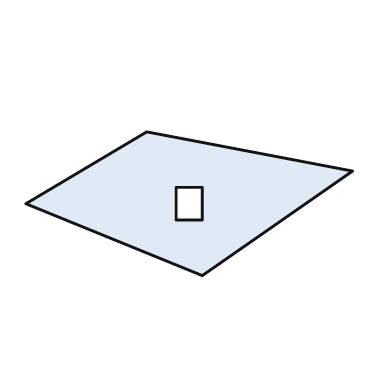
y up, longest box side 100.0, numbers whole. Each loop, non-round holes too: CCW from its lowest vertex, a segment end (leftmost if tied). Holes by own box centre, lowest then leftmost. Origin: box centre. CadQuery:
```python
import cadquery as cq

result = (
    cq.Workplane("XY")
    .moveTo(4.0, -22.0)
    .lineTo(50.0, 10.0)
    .lineTo(-13.0, 22.0)
    .lineTo(-50.0, 0.0)
    .close()
    .moveTo(-4.0, -5.0)
    .lineTo(4.0, -5.0)
    .lineTo(4.0, 5.0)
    .lineTo(-4.0, 5.0)
    .close()
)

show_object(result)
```